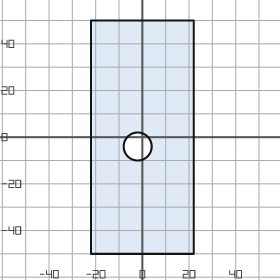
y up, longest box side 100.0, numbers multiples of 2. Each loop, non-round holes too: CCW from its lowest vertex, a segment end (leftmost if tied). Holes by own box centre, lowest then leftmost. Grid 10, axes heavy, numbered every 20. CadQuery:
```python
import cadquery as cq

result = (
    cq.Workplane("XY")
    .moveTo(-22.0, -50.0)
    .lineTo(22.0, -50.0)
    .lineTo(22.0, 50.0)
    .lineTo(-22.0, 50.0)
    .close()
    .moveTo(-2.0, -4.0)
    .circle(6.0)
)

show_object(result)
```